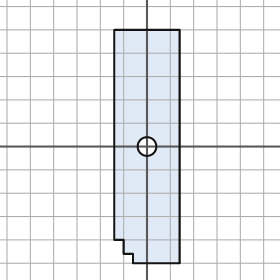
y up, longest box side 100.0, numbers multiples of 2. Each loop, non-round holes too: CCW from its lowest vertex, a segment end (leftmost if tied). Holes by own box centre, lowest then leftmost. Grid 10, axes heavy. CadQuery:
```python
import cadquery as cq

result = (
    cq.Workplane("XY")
    .moveTo(-6.0, -50.0)
    .lineTo(14.0, -50.0)
    .lineTo(14.0, 50.0)
    .lineTo(-14.0, 50.0)
    .lineTo(-14.0, -40.0)
    .lineTo(-10.0, -40.0)
    .lineTo(-10.0, -46.0)
    .lineTo(-6.0, -46.0)
    .close()
    .moveTo(0.0, 0.0)
    .circle(4.0)
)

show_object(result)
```